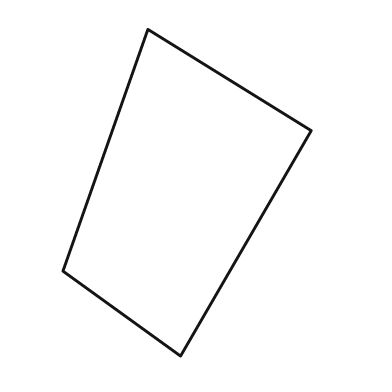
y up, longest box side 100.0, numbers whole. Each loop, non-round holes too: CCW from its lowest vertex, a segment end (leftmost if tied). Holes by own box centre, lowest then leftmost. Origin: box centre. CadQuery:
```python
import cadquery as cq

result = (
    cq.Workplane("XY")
    .moveTo(-2.0, -50.0)
    .lineTo(38.0, 19.0)
    .lineTo(-12.0, 50.0)
    .lineTo(-38.0, -24.0)
    .close()
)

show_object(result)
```